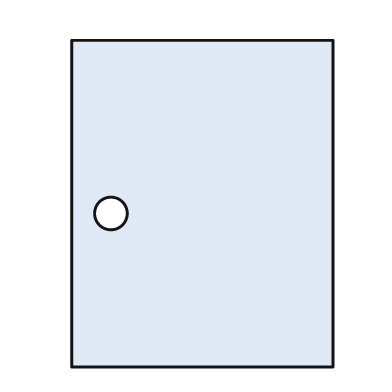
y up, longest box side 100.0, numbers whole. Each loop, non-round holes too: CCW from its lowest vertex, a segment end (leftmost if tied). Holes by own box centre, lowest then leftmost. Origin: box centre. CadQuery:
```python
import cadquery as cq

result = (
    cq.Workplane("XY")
    .moveTo(-40.0, -50.0)
    .lineTo(40.0, -50.0)
    .lineTo(40.0, 50.0)
    .lineTo(-40.0, 50.0)
    .close()
    .moveTo(-28.0, -3.0)
    .circle(5.0)
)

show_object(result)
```